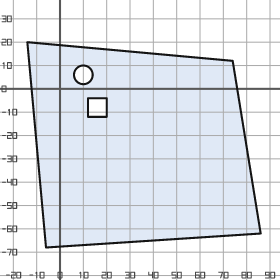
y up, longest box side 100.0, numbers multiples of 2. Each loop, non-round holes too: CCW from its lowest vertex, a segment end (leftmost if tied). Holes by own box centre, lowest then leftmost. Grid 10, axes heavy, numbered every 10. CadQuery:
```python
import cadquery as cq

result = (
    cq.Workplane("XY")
    .moveTo(-6.0, -68.0)
    .lineTo(86.0, -62.0)
    .lineTo(74.0, 12.0)
    .lineTo(-14.0, 20.0)
    .close()
    .moveTo(12.0, -12.0)
    .lineTo(20.0, -12.0)
    .lineTo(20.0, -4.0)
    .lineTo(12.0, -4.0)
    .close()
    .moveTo(10.0, 6.0)
    .circle(4.0)
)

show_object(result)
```